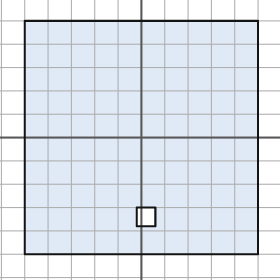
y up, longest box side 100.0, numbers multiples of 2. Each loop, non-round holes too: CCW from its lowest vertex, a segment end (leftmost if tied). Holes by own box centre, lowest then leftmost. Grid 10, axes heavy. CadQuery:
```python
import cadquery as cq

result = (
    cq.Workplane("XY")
    .moveTo(-50.0, -50.0)
    .lineTo(50.0, -50.0)
    .lineTo(50.0, 50.0)
    .lineTo(-50.0, 50.0)
    .close()
    .moveTo(-2.0, -38.0)
    .lineTo(6.0, -38.0)
    .lineTo(6.0, -30.0)
    .lineTo(-2.0, -30.0)
    .close()
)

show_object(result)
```